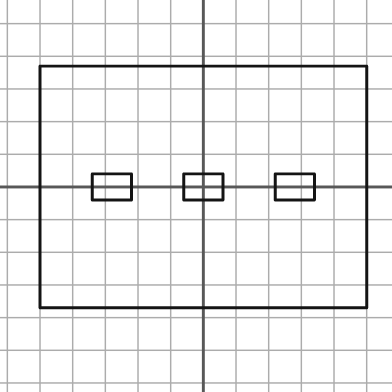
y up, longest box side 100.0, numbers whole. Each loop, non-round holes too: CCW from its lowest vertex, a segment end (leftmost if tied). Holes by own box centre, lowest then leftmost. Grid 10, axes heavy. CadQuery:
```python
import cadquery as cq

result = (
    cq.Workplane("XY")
    .moveTo(-50.0, -37.0)
    .lineTo(50.0, -37.0)
    .lineTo(50.0, 37.0)
    .lineTo(-50.0, 37.0)
    .close()
    .moveTo(-34.0, -4.0)
    .lineTo(-22.0, -4.0)
    .lineTo(-22.0, 4.0)
    .lineTo(-34.0, 4.0)
    .close()
    .moveTo(-6.0, -4.0)
    .lineTo(6.0, -4.0)
    .lineTo(6.0, 4.0)
    .lineTo(-6.0, 4.0)
    .close()
    .moveTo(22.0, -4.0)
    .lineTo(34.0, -4.0)
    .lineTo(34.0, 4.0)
    .lineTo(22.0, 4.0)
    .close()
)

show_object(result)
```